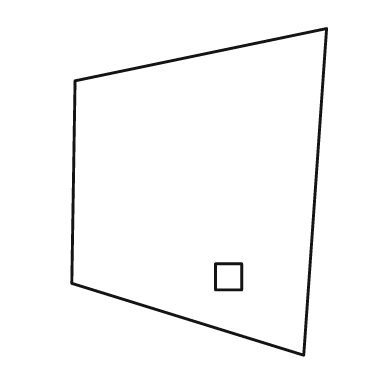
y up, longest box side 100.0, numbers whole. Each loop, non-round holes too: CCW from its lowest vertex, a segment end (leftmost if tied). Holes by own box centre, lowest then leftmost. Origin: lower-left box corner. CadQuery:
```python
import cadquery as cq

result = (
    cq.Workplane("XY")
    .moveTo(71.0, 0.0)
    .lineTo(78.0, 100.0)
    .lineTo(1.0, 84.0)
    .lineTo(0.0, 22.0)
    .close()
    .moveTo(44.0, 20.0)
    .lineTo(52.0, 20.0)
    .lineTo(52.0, 28.0)
    .lineTo(44.0, 28.0)
    .close()
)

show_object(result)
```